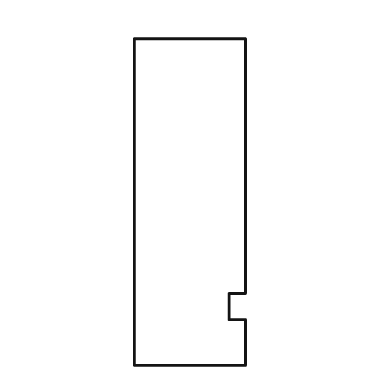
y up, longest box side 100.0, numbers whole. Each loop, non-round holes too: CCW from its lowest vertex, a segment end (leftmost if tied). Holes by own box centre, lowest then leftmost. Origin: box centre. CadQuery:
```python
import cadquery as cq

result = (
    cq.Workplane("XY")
    .moveTo(-17.0, -50.0)
    .lineTo(17.0, -50.0)
    .lineTo(17.0, -36.0)
    .lineTo(12.0, -36.0)
    .lineTo(12.0, -28.0)
    .lineTo(17.0, -28.0)
    .lineTo(17.0, 50.0)
    .lineTo(-17.0, 50.0)
    .close()
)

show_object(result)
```